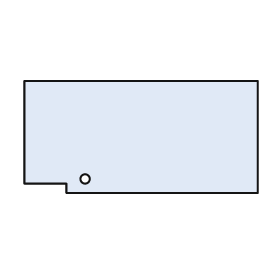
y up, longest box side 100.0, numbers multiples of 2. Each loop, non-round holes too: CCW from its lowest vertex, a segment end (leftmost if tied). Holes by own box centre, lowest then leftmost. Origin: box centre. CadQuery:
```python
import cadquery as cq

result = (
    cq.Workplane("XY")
    .moveTo(-32.0, -24.0)
    .lineTo(50.0, -24.0)
    .lineTo(50.0, 24.0)
    .lineTo(-50.0, 24.0)
    .lineTo(-50.0, -20.0)
    .lineTo(-32.0, -20.0)
    .close()
    .moveTo(-24.0, -18.0)
    .circle(2.0)
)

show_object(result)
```